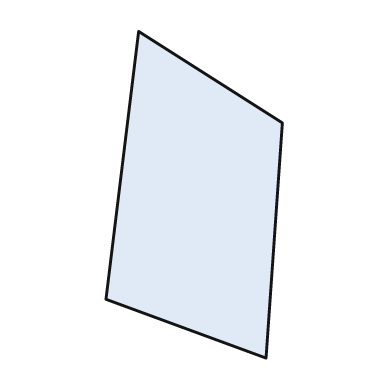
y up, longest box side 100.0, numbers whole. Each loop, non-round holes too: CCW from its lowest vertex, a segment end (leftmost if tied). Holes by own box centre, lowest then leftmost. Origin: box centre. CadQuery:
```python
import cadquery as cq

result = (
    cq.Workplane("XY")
    .moveTo(22.0, -50.0)
    .lineTo(27.0, 22.0)
    .lineTo(-17.0, 50.0)
    .lineTo(-27.0, -32.0)
    .close()
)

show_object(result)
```